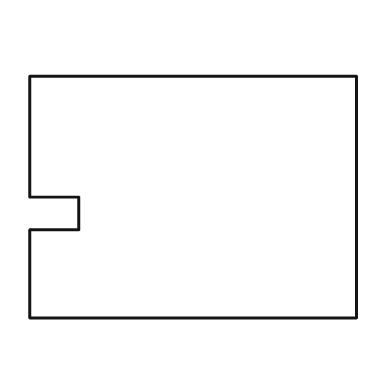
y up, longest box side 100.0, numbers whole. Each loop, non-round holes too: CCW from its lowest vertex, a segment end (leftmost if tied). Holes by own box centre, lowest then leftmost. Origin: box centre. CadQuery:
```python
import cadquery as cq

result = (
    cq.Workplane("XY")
    .moveTo(-50.0, -37.0)
    .lineTo(50.0, -37.0)
    .lineTo(50.0, 37.0)
    .lineTo(-50.0, 37.0)
    .lineTo(-50.0, 0.0)
    .lineTo(-35.0, 0.0)
    .lineTo(-35.0, -10.0)
    .lineTo(-50.0, -10.0)
    .close()
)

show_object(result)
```